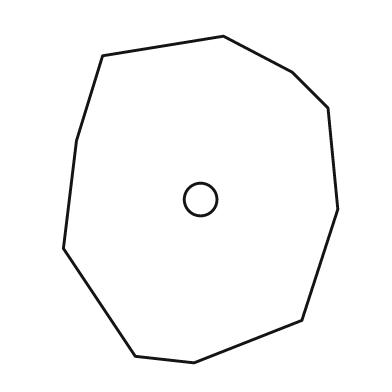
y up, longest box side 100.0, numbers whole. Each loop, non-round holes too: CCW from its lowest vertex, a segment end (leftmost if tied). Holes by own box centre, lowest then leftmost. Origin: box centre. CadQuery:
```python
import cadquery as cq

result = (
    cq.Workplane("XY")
    .moveTo(-2.0, -50.0)
    .lineTo(31.0, -37.0)
    .lineTo(42.0, -3.0)
    .lineTo(39.0, 28.0)
    .lineTo(28.0, 39.0)
    .lineTo(7.0, 50.0)
    .lineTo(-30.0, 44.0)
    .lineTo(-38.0, 18.0)
    .lineTo(-42.0, -15.0)
    .lineTo(-20.0, -48.0)
    .close()
    .moveTo(0.0, 0.0)
    .circle(5.0)
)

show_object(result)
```